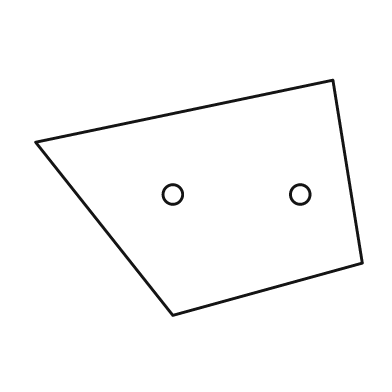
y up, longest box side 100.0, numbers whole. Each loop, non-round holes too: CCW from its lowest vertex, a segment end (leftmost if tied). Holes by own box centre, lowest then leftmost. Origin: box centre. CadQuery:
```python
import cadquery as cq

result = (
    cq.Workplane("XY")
    .moveTo(-8.0, -36.0)
    .lineTo(50.0, -20.0)
    .lineTo(41.0, 36.0)
    .lineTo(-50.0, 17.0)
    .close()
    .moveTo(-8.0, 1.0)
    .circle(3.0)
    .moveTo(31.0, 1.0)
    .circle(3.0)
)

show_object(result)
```